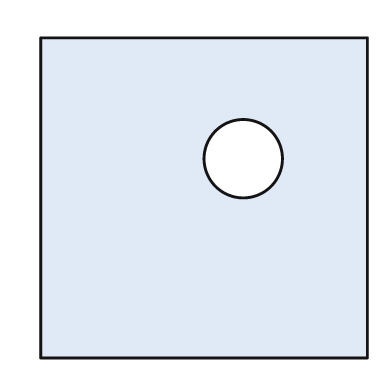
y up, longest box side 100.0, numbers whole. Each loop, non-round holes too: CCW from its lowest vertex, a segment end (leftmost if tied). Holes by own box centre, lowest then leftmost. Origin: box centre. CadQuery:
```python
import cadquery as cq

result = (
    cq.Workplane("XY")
    .moveTo(-50.0, -49.0)
    .lineTo(50.0, -49.0)
    .lineTo(50.0, 49.0)
    .lineTo(-50.0, 49.0)
    .close()
    .moveTo(12.0, 12.0)
    .circle(12.0)
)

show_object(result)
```